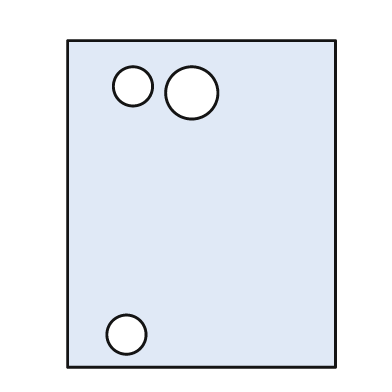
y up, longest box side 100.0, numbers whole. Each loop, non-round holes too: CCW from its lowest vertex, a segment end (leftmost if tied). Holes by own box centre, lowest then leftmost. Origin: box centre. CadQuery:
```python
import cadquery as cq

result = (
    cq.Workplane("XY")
    .moveTo(-41.0, -50.0)
    .lineTo(41.0, -50.0)
    .lineTo(41.0, 50.0)
    .lineTo(-41.0, 50.0)
    .close()
    .moveTo(-23.0, -40.0)
    .circle(6.0)
    .moveTo(-3.0, 34.0)
    .circle(8.0)
    .moveTo(-21.0, 36.0)
    .circle(6.0)
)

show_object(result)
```